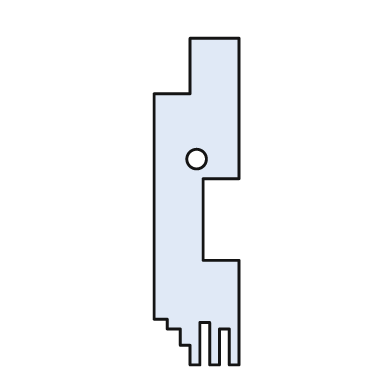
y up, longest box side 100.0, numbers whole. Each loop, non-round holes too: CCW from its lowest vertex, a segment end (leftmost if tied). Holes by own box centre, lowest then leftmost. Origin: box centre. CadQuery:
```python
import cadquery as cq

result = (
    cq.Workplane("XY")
    .moveTo(-2.0, -50.0)
    .lineTo(1.0, -50.0)
    .lineTo(1.0, -37.0)
    .lineTo(4.0, -37.0)
    .lineTo(4.0, -50.0)
    .lineTo(7.0, -50.0)
    .lineTo(7.0, -39.0)
    .lineTo(10.0, -39.0)
    .lineTo(10.0, -50.0)
    .lineTo(13.0, -50.0)
    .lineTo(13.0, -18.0)
    .lineTo(2.0, -18.0)
    .lineTo(2.0, 7.0)
    .lineTo(13.0, 7.0)
    .lineTo(13.0, 50.0)
    .lineTo(-2.0, 50.0)
    .lineTo(-2.0, 33.0)
    .lineTo(-13.0, 33.0)
    .lineTo(-13.0, -36.0)
    .lineTo(-9.0, -36.0)
    .lineTo(-9.0, -39.0)
    .lineTo(-5.0, -39.0)
    .lineTo(-5.0, -44.0)
    .lineTo(-2.0, -44.0)
    .close()
    .moveTo(0.0, 13.0)
    .circle(3.0)
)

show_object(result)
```